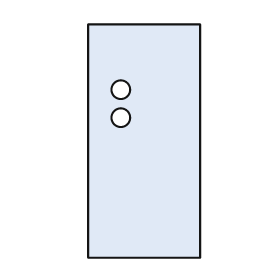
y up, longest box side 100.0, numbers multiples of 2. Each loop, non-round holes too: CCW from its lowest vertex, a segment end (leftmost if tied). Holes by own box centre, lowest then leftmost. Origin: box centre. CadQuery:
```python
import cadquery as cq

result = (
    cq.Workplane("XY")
    .moveTo(-24.0, -50.0)
    .lineTo(24.0, -50.0)
    .lineTo(24.0, 50.0)
    .lineTo(-24.0, 50.0)
    .close()
    .moveTo(-10.0, 10.0)
    .circle(4.0)
    .moveTo(-10.0, 22.0)
    .circle(4.0)
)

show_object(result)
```